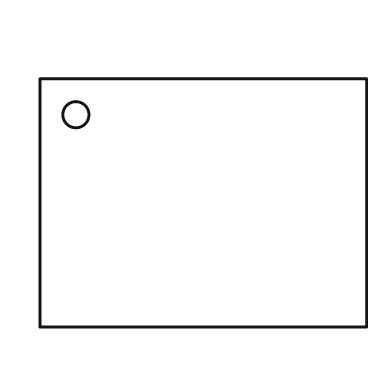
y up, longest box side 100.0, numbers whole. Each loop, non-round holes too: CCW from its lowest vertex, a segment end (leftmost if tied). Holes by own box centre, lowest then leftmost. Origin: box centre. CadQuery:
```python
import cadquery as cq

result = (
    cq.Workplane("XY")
    .moveTo(-50.0, -38.0)
    .lineTo(50.0, -38.0)
    .lineTo(50.0, 38.0)
    .lineTo(-50.0, 38.0)
    .close()
    .moveTo(-39.0, 27.0)
    .circle(4.0)
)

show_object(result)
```